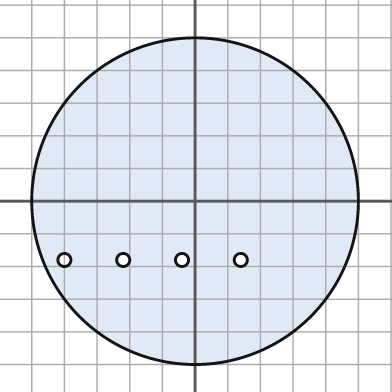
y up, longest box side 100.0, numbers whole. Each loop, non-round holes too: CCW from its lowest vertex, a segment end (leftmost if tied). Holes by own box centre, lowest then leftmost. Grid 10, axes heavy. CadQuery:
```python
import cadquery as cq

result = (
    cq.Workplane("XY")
    .moveTo(0.0, 0.0)
    .circle(50.0)
    .moveTo(-40.0, -18.0)
    .circle(2.0)
    .moveTo(-22.0, -18.0)
    .circle(2.0)
    .moveTo(-4.0, -18.0)
    .circle(2.0)
    .moveTo(14.0, -18.0)
    .circle(2.0)
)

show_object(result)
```